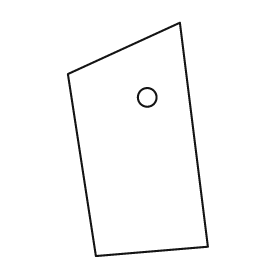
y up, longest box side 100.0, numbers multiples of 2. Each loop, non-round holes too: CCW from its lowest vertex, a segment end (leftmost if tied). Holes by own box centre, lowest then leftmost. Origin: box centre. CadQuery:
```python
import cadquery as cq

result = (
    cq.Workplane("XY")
    .moveTo(-18.0, -50.0)
    .lineTo(30.0, -46.0)
    .lineTo(18.0, 50.0)
    .lineTo(-30.0, 28.0)
    .close()
    .moveTo(4.0, 18.0)
    .circle(4.0)
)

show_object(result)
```